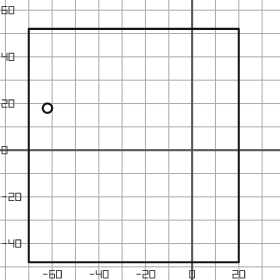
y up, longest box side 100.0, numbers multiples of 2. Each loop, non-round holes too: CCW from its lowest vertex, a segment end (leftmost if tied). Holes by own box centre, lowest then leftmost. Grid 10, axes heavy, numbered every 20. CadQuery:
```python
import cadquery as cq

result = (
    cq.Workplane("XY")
    .moveTo(-70.0, -48.0)
    .lineTo(20.0, -48.0)
    .lineTo(20.0, 52.0)
    .lineTo(-70.0, 52.0)
    .close()
    .moveTo(-62.0, 18.0)
    .circle(2.0)
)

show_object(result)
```